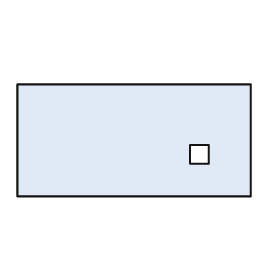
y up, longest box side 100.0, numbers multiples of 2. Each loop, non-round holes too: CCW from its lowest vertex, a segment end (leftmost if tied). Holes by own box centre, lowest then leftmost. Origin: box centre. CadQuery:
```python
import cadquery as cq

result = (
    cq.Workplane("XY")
    .moveTo(-50.0, -24.0)
    .lineTo(50.0, -24.0)
    .lineTo(50.0, 24.0)
    .lineTo(-50.0, 24.0)
    .close()
    .moveTo(24.0, -10.0)
    .lineTo(32.0, -10.0)
    .lineTo(32.0, -2.0)
    .lineTo(24.0, -2.0)
    .close()
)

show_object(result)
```